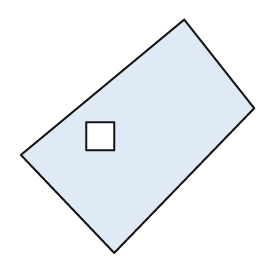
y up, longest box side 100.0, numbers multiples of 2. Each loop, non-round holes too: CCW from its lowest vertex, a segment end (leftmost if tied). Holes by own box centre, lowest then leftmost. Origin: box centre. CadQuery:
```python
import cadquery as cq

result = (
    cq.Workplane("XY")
    .moveTo(-10.0, -50.0)
    .lineTo(50.0, 12.0)
    .lineTo(20.0, 50.0)
    .lineTo(-50.0, -8.0)
    .close()
    .moveTo(-22.0, -6.0)
    .lineTo(-10.0, -6.0)
    .lineTo(-10.0, 6.0)
    .lineTo(-22.0, 6.0)
    .close()
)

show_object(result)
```